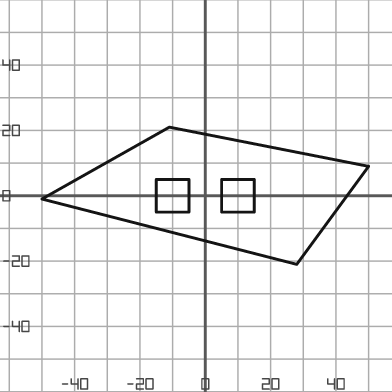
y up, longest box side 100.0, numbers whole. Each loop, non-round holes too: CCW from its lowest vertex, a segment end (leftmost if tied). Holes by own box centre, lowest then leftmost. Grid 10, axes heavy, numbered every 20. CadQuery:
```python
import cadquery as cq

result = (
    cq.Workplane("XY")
    .moveTo(28.0, -21.0)
    .lineTo(50.0, 9.0)
    .lineTo(-11.0, 21.0)
    .lineTo(-50.0, -1.0)
    .close()
    .moveTo(-15.0, -5.0)
    .lineTo(-5.0, -5.0)
    .lineTo(-5.0, 5.0)
    .lineTo(-15.0, 5.0)
    .close()
    .moveTo(5.0, -5.0)
    .lineTo(15.0, -5.0)
    .lineTo(15.0, 5.0)
    .lineTo(5.0, 5.0)
    .close()
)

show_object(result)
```